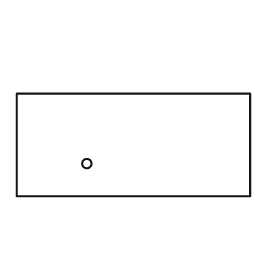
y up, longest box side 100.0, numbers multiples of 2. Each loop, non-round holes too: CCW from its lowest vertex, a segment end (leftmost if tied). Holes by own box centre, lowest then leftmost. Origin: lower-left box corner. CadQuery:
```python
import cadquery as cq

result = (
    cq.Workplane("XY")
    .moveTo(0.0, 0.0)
    .lineTo(100.0, 0.0)
    .lineTo(100.0, 44.0)
    .lineTo(0.0, 44.0)
    .close()
    .moveTo(30.0, 14.0)
    .circle(2.0)
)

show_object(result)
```